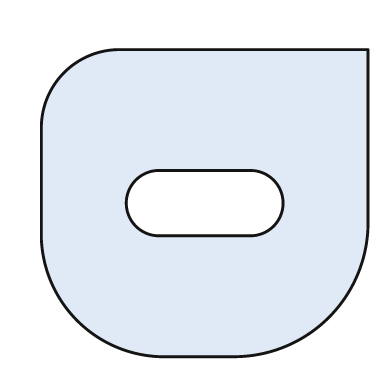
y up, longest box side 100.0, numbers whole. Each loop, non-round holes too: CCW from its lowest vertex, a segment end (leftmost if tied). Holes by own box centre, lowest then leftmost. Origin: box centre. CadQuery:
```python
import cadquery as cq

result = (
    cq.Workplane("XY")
    .moveTo(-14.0, -47.0)
    .lineTo(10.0, -47.0)
    .threePointArc((38.0, -35.0), (50.0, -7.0))
    .lineTo(50.0, 47.0)
    .lineTo(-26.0, 47.0)
    .threePointArc((-43.0, 40.0), (-50.0, 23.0))
    .lineTo(-50.0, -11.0)
    .threePointArc((-39.0, -36.0), (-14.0, -47.0))
    .close()
    .moveTo(-14.0, -10.0)
    .lineTo(14.0, -10.0)
    .threePointArc((24.0, 0.0), (14.0, 10.0))
    .lineTo(-14.0, 10.0)
    .threePointArc((-24.0, 0.0), (-14.0, -10.0))
    .close()
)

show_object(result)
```